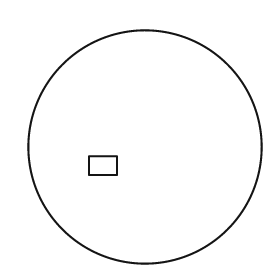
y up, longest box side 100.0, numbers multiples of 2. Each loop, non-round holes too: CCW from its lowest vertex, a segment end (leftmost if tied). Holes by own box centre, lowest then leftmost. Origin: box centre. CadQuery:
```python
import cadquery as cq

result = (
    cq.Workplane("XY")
    .moveTo(0.0, 0.0)
    .circle(50.0)
    .moveTo(-24.0, -12.0)
    .lineTo(-12.0, -12.0)
    .lineTo(-12.0, -4.0)
    .lineTo(-24.0, -4.0)
    .close()
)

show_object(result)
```